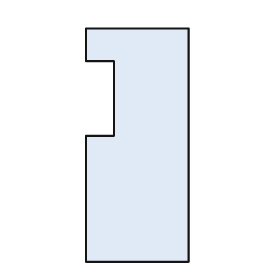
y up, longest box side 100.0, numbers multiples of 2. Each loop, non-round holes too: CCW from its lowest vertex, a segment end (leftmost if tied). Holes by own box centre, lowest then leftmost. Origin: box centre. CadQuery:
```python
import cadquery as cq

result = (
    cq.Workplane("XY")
    .moveTo(-22.0, -50.0)
    .lineTo(22.0, -50.0)
    .lineTo(22.0, 50.0)
    .lineTo(-22.0, 50.0)
    .lineTo(-22.0, 36.0)
    .lineTo(-10.0, 36.0)
    .lineTo(-10.0, 4.0)
    .lineTo(-22.0, 4.0)
    .close()
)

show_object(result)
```